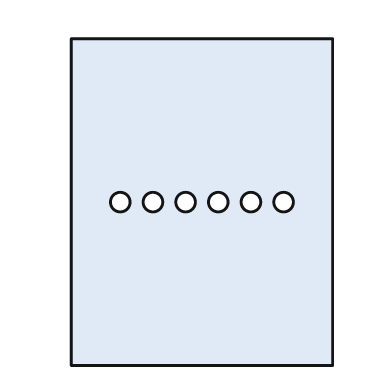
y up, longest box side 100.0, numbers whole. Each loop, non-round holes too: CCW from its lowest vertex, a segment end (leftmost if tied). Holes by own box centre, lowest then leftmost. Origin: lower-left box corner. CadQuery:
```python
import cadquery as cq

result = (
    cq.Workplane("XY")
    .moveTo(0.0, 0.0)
    .lineTo(80.0, 0.0)
    .lineTo(80.0, 100.0)
    .lineTo(0.0, 100.0)
    .close()
    .moveTo(15.0, 50.0)
    .circle(3.0)
    .moveTo(25.0, 50.0)
    .circle(3.0)
    .moveTo(35.0, 50.0)
    .circle(3.0)
    .moveTo(45.0, 50.0)
    .circle(3.0)
    .moveTo(55.0, 50.0)
    .circle(3.0)
    .moveTo(65.0, 50.0)
    .circle(3.0)
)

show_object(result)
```